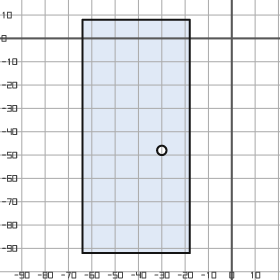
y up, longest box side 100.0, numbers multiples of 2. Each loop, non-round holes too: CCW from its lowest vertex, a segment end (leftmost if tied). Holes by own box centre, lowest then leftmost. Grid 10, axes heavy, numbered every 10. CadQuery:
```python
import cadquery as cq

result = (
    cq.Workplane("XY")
    .moveTo(-64.0, -92.0)
    .lineTo(-18.0, -92.0)
    .lineTo(-18.0, 8.0)
    .lineTo(-64.0, 8.0)
    .close()
    .moveTo(-30.0, -48.0)
    .circle(2.0)
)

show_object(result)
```